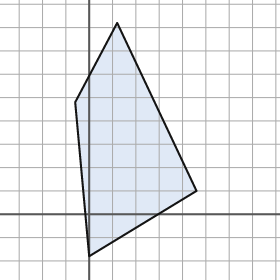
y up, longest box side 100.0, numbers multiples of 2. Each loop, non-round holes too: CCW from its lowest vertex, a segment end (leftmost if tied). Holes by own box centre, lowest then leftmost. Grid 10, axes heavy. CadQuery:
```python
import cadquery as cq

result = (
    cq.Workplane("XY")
    .moveTo(0.0, -18.0)
    .lineTo(46.0, 10.0)
    .lineTo(12.0, 82.0)
    .lineTo(-6.0, 48.0)
    .close()
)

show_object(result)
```